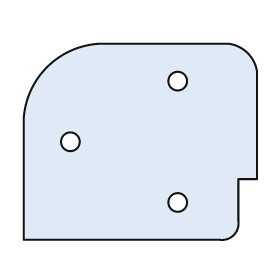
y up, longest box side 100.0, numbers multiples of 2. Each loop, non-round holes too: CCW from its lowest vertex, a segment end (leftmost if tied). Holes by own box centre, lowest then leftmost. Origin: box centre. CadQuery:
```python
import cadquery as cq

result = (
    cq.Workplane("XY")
    .moveTo(-50.0, -42.0)
    .lineTo(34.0, -42.0)
    .threePointArc((40.0, -40.0), (42.0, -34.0))
    .lineTo(42.0, -16.0)
    .lineTo(50.0, -16.0)
    .lineTo(50.0, 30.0)
    .threePointArc((46.0, 38.0), (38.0, 42.0))
    .lineTo(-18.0, 42.0)
    .threePointArc((-40.0, 32.0), (-50.0, 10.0))
    .close()
    .moveTo(16.0, -26.0)
    .circle(4.0)
    .moveTo(-30.0, 0.0)
    .circle(4.0)
    .moveTo(16.0, 26.0)
    .circle(4.0)
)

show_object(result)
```